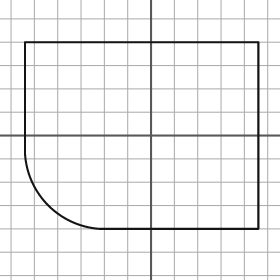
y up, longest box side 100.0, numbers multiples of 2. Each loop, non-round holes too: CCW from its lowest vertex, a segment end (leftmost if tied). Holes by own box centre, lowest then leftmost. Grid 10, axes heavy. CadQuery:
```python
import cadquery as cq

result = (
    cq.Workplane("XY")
    .moveTo(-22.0, -40.0)
    .lineTo(46.0, -40.0)
    .lineTo(46.0, 40.0)
    .lineTo(-54.0, 40.0)
    .lineTo(-54.0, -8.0)
    .threePointArc((-44.0, -30.0), (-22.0, -40.0))
    .close()
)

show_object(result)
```